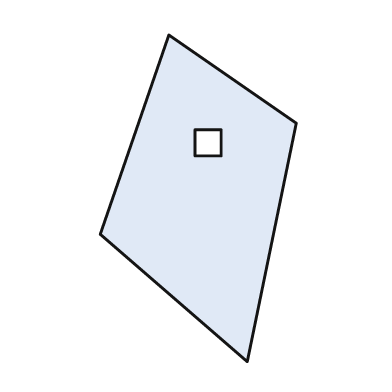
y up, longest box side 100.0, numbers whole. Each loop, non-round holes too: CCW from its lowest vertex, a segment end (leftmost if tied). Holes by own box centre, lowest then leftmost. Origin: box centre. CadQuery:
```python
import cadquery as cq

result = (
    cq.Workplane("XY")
    .moveTo(15.0, -50.0)
    .lineTo(30.0, 23.0)
    .lineTo(-9.0, 50.0)
    .lineTo(-30.0, -11.0)
    .close()
    .moveTo(-1.0, 13.0)
    .lineTo(7.0, 13.0)
    .lineTo(7.0, 21.0)
    .lineTo(-1.0, 21.0)
    .close()
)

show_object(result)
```